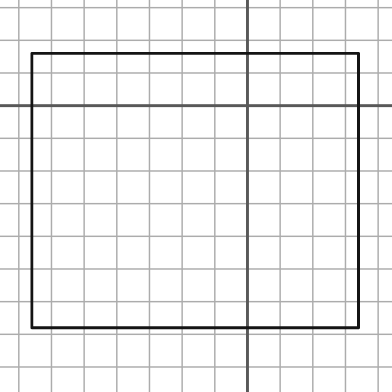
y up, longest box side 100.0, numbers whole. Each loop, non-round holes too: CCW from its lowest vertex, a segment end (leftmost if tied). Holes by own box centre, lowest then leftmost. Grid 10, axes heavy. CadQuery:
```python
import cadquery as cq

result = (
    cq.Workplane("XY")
    .moveTo(-66.0, -68.0)
    .lineTo(34.0, -68.0)
    .lineTo(34.0, 16.0)
    .lineTo(-66.0, 16.0)
    .close()
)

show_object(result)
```